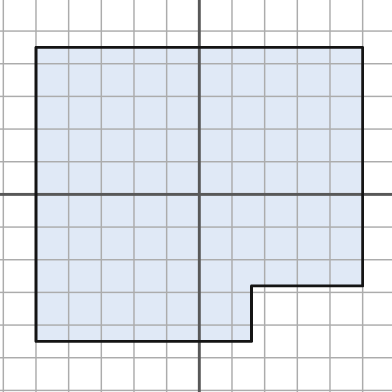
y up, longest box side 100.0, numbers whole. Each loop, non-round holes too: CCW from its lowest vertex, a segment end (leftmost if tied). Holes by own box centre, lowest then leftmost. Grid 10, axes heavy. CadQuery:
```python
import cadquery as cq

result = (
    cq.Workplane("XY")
    .moveTo(-50.0, -45.0)
    .lineTo(16.0, -45.0)
    .lineTo(16.0, -28.0)
    .lineTo(50.0, -28.0)
    .lineTo(50.0, 45.0)
    .lineTo(-50.0, 45.0)
    .close()
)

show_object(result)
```